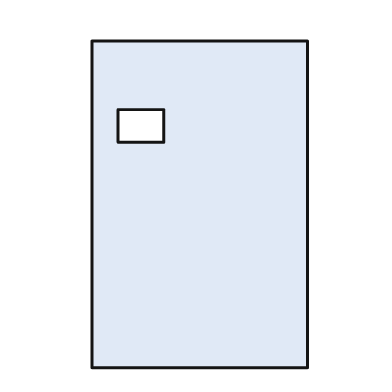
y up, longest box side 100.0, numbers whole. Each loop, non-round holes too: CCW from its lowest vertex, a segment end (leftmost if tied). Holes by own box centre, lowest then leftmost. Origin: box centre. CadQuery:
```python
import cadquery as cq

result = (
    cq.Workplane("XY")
    .moveTo(-33.0, -50.0)
    .lineTo(33.0, -50.0)
    .lineTo(33.0, 50.0)
    .lineTo(-33.0, 50.0)
    .close()
    .moveTo(-25.0, 19.0)
    .lineTo(-11.0, 19.0)
    .lineTo(-11.0, 29.0)
    .lineTo(-25.0, 29.0)
    .close()
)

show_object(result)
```